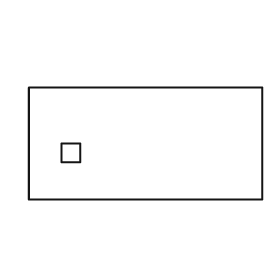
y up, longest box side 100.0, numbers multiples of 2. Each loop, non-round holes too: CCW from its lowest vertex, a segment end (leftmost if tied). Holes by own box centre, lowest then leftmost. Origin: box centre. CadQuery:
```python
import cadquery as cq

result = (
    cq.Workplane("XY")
    .moveTo(-50.0, -24.0)
    .lineTo(50.0, -24.0)
    .lineTo(50.0, 24.0)
    .lineTo(-50.0, 24.0)
    .close()
    .moveTo(-36.0, -8.0)
    .lineTo(-28.0, -8.0)
    .lineTo(-28.0, 0.0)
    .lineTo(-36.0, 0.0)
    .close()
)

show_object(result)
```